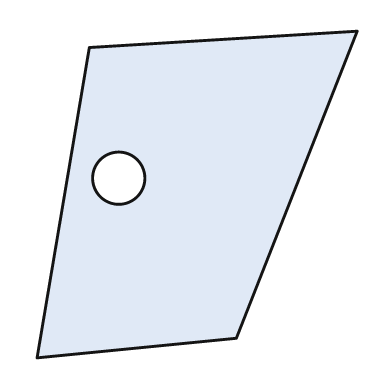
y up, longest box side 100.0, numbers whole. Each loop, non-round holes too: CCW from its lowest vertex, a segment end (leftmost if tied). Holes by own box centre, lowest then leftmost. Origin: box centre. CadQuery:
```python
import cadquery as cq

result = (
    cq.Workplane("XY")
    .moveTo(-49.0, -50.0)
    .lineTo(12.0, -44.0)
    .lineTo(49.0, 50.0)
    .lineTo(-33.0, 45.0)
    .close()
    .moveTo(-24.0, 5.0)
    .circle(8.0)
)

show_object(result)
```